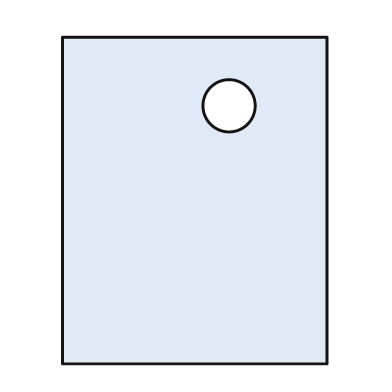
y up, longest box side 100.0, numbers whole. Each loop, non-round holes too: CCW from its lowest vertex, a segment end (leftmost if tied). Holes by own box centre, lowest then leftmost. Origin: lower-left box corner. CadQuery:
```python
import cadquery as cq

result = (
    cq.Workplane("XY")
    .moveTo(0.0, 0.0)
    .lineTo(81.0, 0.0)
    .lineTo(81.0, 100.0)
    .lineTo(0.0, 100.0)
    .close()
    .moveTo(51.0, 79.0)
    .circle(8.0)
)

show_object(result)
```